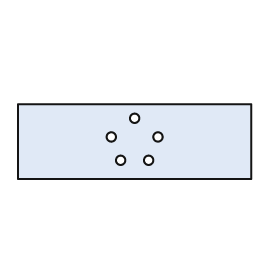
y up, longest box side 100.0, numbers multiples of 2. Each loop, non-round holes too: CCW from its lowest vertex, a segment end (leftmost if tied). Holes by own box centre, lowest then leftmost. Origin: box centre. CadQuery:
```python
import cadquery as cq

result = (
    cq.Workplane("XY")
    .moveTo(-50.0, -16.0)
    .lineTo(50.0, -16.0)
    .lineTo(50.0, 16.0)
    .lineTo(-50.0, 16.0)
    .close()
    .moveTo(-6.0, -8.0)
    .circle(2.0)
    .moveTo(6.0, -8.0)
    .circle(2.0)
    .moveTo(-10.0, 2.0)
    .circle(2.0)
    .moveTo(10.0, 2.0)
    .circle(2.0)
    .moveTo(0.0, 10.0)
    .circle(2.0)
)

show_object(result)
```